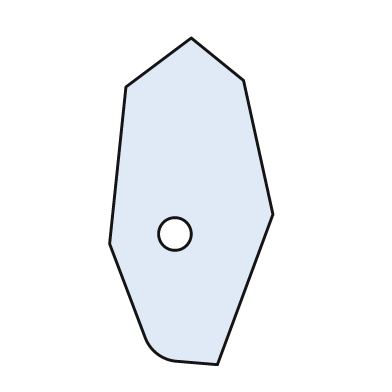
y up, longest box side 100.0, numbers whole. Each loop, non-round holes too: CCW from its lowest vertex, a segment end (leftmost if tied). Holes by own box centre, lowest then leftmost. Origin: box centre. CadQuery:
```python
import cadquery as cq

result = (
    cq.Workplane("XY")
    .moveTo(8.0, -50.0)
    .lineTo(25.0, -4.0)
    .lineTo(16.0, 37.0)
    .lineTo(0.0, 50.0)
    .lineTo(-20.0, 35.0)
    .lineTo(-25.0, -13.0)
    .lineTo(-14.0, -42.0)
    .threePointArc((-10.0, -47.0), (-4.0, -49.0))
    .close()
    .moveTo(-5.0, -10.0)
    .circle(5.0)
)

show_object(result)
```